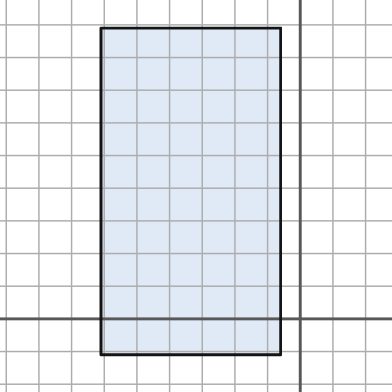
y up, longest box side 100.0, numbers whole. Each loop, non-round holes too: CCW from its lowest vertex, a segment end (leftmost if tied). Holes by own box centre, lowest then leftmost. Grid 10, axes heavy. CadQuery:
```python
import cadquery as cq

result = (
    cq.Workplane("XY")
    .moveTo(-61.0, -11.0)
    .lineTo(-6.0, -11.0)
    .lineTo(-6.0, 89.0)
    .lineTo(-61.0, 89.0)
    .close()
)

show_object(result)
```